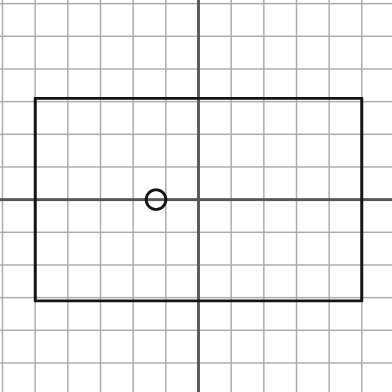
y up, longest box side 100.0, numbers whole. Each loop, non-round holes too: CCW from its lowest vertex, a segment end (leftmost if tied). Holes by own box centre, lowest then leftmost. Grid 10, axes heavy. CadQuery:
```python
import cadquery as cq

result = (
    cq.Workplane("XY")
    .moveTo(-50.0, -31.0)
    .lineTo(50.0, -31.0)
    .lineTo(50.0, 31.0)
    .lineTo(-50.0, 31.0)
    .close()
    .moveTo(-13.0, 0.0)
    .circle(3.0)
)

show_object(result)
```